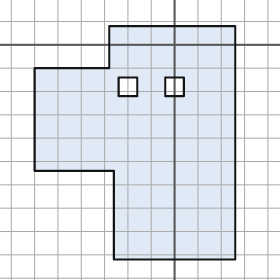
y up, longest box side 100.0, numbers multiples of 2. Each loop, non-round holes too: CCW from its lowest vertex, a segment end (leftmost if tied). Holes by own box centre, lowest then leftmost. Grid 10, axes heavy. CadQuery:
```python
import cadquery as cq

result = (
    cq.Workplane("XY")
    .moveTo(-26.0, -92.0)
    .lineTo(26.0, -92.0)
    .lineTo(26.0, 8.0)
    .lineTo(-28.0, 8.0)
    .lineTo(-28.0, -10.0)
    .lineTo(-60.0, -10.0)
    .lineTo(-60.0, -54.0)
    .lineTo(-26.0, -54.0)
    .close()
    .moveTo(-24.0, -22.0)
    .lineTo(-16.0, -22.0)
    .lineTo(-16.0, -14.0)
    .lineTo(-24.0, -14.0)
    .close()
    .moveTo(-4.0, -22.0)
    .lineTo(4.0, -22.0)
    .lineTo(4.0, -14.0)
    .lineTo(-4.0, -14.0)
    .close()
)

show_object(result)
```